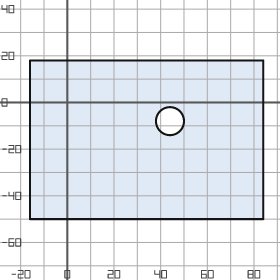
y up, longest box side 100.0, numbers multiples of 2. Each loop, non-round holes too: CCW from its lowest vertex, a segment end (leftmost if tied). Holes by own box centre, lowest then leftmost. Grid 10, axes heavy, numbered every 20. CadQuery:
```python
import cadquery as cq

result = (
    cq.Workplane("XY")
    .moveTo(-16.0, -50.0)
    .lineTo(84.0, -50.0)
    .lineTo(84.0, 18.0)
    .lineTo(-16.0, 18.0)
    .close()
    .moveTo(44.0, -8.0)
    .circle(6.0)
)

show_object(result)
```